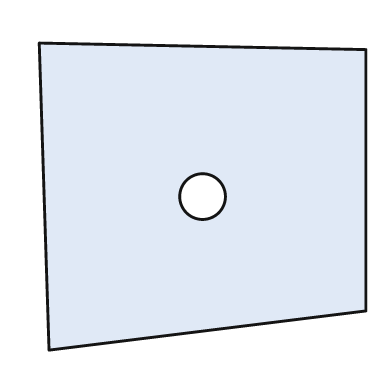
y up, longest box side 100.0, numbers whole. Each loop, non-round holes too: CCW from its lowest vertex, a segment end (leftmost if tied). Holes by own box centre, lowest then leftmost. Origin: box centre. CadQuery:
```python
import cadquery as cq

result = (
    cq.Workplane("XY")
    .moveTo(-47.0, -47.0)
    .lineTo(50.0, -35.0)
    .lineTo(50.0, 45.0)
    .lineTo(-50.0, 47.0)
    .close()
    .moveTo(0.0, 0.0)
    .circle(7.0)
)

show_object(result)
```